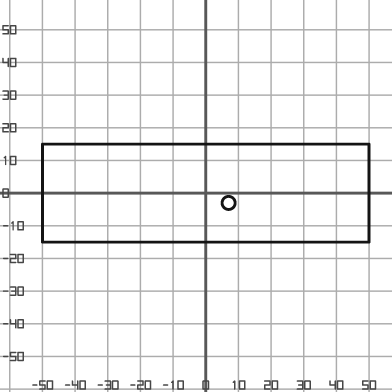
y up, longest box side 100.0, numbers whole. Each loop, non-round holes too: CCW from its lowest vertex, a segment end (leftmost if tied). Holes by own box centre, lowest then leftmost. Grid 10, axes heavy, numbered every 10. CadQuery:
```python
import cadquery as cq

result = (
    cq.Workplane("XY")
    .moveTo(-50.0, -15.0)
    .lineTo(50.0, -15.0)
    .lineTo(50.0, 15.0)
    .lineTo(-50.0, 15.0)
    .close()
    .moveTo(7.0, -3.0)
    .circle(2.0)
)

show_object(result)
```